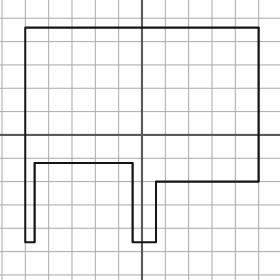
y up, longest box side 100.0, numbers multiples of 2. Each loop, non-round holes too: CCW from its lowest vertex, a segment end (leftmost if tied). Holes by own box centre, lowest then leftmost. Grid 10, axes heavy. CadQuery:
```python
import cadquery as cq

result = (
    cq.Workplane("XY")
    .moveTo(-50.0, -46.0)
    .lineTo(-46.0, -46.0)
    .lineTo(-46.0, -12.0)
    .lineTo(-4.0, -12.0)
    .lineTo(-4.0, -46.0)
    .lineTo(6.0, -46.0)
    .lineTo(6.0, -20.0)
    .lineTo(50.0, -20.0)
    .lineTo(50.0, 46.0)
    .lineTo(-50.0, 46.0)
    .close()
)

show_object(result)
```